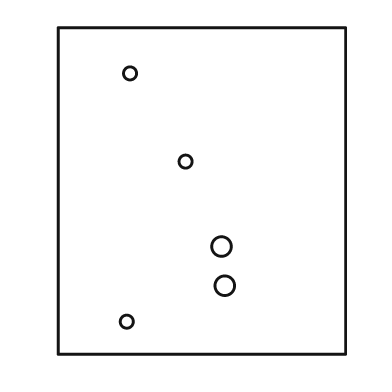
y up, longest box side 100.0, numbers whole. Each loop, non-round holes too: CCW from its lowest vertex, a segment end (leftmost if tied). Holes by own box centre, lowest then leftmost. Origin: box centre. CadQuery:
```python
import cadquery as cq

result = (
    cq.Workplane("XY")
    .moveTo(-44.0, -50.0)
    .lineTo(44.0, -50.0)
    .lineTo(44.0, 50.0)
    .lineTo(-44.0, 50.0)
    .close()
    .moveTo(-23.0, -40.0)
    .circle(2.0)
    .moveTo(7.0, -29.0)
    .circle(3.0)
    .moveTo(6.0, -17.0)
    .circle(3.0)
    .moveTo(-5.0, 9.0)
    .circle(2.0)
    .moveTo(-22.0, 36.0)
    .circle(2.0)
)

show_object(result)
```